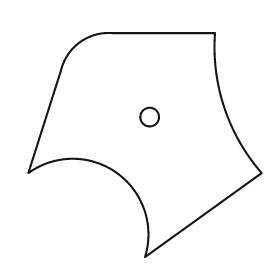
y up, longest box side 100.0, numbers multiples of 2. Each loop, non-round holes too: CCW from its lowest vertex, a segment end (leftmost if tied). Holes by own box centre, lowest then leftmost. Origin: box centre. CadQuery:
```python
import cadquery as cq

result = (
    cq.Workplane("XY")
    .moveTo(0.0, -48.0)
    .lineTo(50.0, -12.0)
    .threePointArc((34.0, 16.0), (30.0, 48.0))
    .lineTo(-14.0, 48.0)
    .threePointArc((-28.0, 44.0), (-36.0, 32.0))
    .lineTo(-50.0, -12.0)
    .threePointArc((-12.0, -12.0), (0.0, -48.0))
    .close()
    .moveTo(2.0, 12.0)
    .circle(4.0)
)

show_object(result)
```